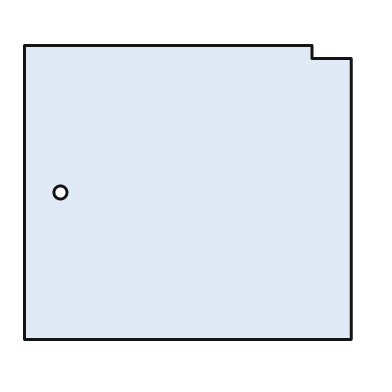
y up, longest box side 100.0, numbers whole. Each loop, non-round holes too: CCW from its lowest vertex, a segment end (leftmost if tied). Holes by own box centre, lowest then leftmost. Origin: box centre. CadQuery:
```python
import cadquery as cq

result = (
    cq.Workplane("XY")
    .moveTo(-50.0, -45.0)
    .lineTo(50.0, -45.0)
    .lineTo(50.0, 41.0)
    .lineTo(38.0, 41.0)
    .lineTo(38.0, 45.0)
    .lineTo(-50.0, 45.0)
    .close()
    .moveTo(-39.0, 0.0)
    .circle(2.0)
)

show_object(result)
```